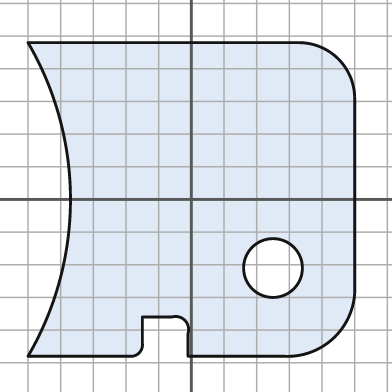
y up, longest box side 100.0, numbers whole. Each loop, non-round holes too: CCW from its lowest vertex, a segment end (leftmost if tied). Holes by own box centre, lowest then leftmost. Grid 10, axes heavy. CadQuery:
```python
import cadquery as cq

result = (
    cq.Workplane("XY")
    .moveTo(-50.0, -48.0)
    .lineTo(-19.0, -48.0)
    .threePointArc((-16.0, -47.0), (-15.0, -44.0))
    .lineTo(-15.0, -36.0)
    .lineTo(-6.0, -36.0)
    .threePointArc((-2.0, -37.0), (-1.0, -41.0))
    .lineTo(-1.0, -48.0)
    .lineTo(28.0, -48.0)
    .threePointArc((44.0, -42.0), (50.0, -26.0))
    .lineTo(50.0, 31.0)
    .threePointArc((45.0, 43.0), (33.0, 48.0))
    .lineTo(-50.0, 48.0)
    .threePointArc((-37.0, 0.0), (-50.0, -48.0))
    .close()
    .moveTo(25.0, -21.0)
    .circle(9.0)
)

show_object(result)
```